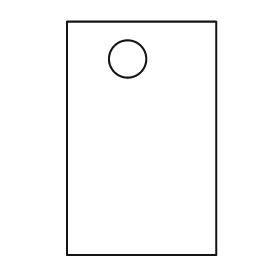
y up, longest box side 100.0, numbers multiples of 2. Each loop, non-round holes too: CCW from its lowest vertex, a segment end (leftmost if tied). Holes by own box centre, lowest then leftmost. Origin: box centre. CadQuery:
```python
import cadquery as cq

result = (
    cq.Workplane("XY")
    .moveTo(-32.0, -50.0)
    .lineTo(32.0, -50.0)
    .lineTo(32.0, 50.0)
    .lineTo(-32.0, 50.0)
    .close()
    .moveTo(-6.0, 34.0)
    .circle(8.0)
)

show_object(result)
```